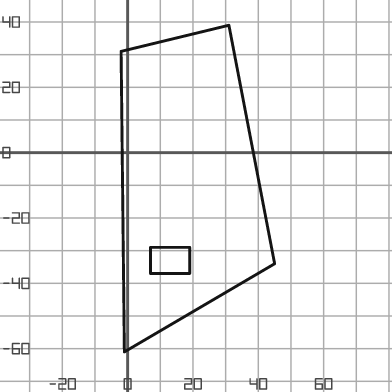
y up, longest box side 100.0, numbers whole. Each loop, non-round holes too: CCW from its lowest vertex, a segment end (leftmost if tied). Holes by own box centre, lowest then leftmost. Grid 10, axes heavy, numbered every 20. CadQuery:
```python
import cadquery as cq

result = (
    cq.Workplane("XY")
    .moveTo(-1.0, -61.0)
    .lineTo(45.0, -34.0)
    .lineTo(31.0, 39.0)
    .lineTo(-2.0, 31.0)
    .close()
    .moveTo(7.0, -37.0)
    .lineTo(19.0, -37.0)
    .lineTo(19.0, -29.0)
    .lineTo(7.0, -29.0)
    .close()
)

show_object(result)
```